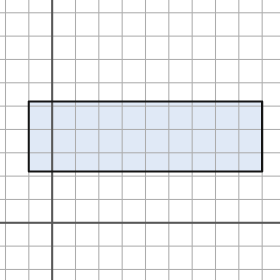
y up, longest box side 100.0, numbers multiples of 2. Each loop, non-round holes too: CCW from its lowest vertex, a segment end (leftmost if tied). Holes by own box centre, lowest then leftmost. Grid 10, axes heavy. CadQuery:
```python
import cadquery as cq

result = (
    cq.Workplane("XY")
    .moveTo(-10.0, 22.0)
    .lineTo(90.0, 22.0)
    .lineTo(90.0, 52.0)
    .lineTo(-10.0, 52.0)
    .close()
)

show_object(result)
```